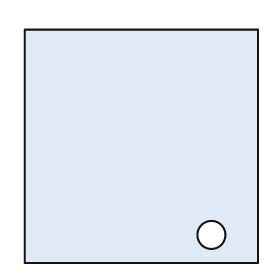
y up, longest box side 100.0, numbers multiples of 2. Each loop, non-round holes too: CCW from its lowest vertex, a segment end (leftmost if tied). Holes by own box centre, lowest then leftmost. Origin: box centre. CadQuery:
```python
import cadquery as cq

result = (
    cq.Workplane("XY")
    .moveTo(-50.0, -50.0)
    .lineTo(50.0, -50.0)
    .lineTo(50.0, 50.0)
    .lineTo(-50.0, 50.0)
    .close()
    .moveTo(30.0, -38.0)
    .circle(6.0)
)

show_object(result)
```